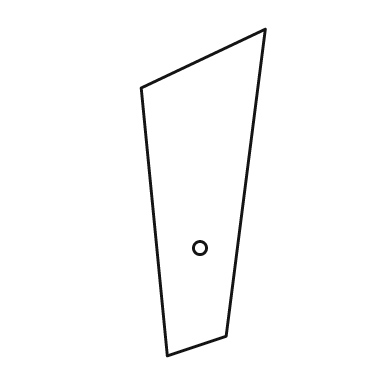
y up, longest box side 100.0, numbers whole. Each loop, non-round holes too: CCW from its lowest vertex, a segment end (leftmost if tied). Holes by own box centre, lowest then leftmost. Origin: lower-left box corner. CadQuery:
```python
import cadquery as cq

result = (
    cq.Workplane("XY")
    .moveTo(8.0, 0.0)
    .lineTo(26.0, 6.0)
    .lineTo(38.0, 100.0)
    .lineTo(0.0, 82.0)
    .close()
    .moveTo(18.0, 33.0)
    .circle(2.0)
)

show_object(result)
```